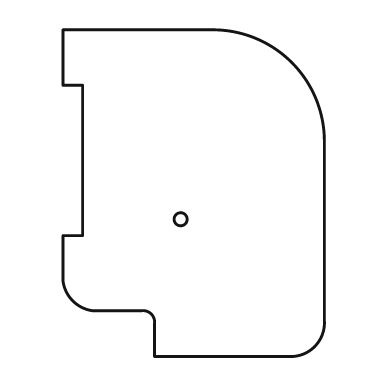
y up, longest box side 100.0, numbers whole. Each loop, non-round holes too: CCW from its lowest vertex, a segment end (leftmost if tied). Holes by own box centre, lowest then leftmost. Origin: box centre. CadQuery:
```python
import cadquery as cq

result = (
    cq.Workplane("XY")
    .moveTo(-12.0, -50.0)
    .lineTo(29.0, -50.0)
    .threePointArc((37.0, -47.0), (40.0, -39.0))
    .lineTo(40.0, 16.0)
    .threePointArc((30.0, 40.0), (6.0, 50.0))
    .lineTo(-40.0, 50.0)
    .lineTo(-40.0, 33.0)
    .lineTo(-34.0, 33.0)
    .lineTo(-34.0, -13.0)
    .lineTo(-40.0, -13.0)
    .lineTo(-40.0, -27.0)
    .threePointArc((-37.0, -33.0), (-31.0, -36.0))
    .lineTo(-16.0, -36.0)
    .threePointArc((-13.0, -37.0), (-12.0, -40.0))
    .close()
    .moveTo(-4.0, -8.0)
    .circle(2.0)
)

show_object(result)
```